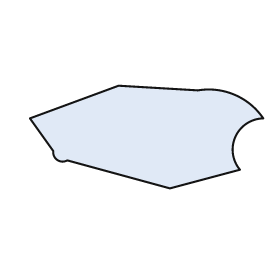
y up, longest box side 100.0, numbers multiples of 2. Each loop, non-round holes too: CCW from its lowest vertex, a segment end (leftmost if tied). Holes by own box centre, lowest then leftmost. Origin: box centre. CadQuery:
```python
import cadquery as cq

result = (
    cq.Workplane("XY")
    .moveTo(10.0, -22.0)
    .lineTo(40.0, -14.0)
    .threePointArc((38.0, 0.0), (50.0, 8.0))
    .threePointArc((38.0, 18.0), (22.0, 20.0))
    .lineTo(-12.0, 22.0)
    .lineTo(-50.0, 8.0)
    .lineTo(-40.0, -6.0)
    .threePointArc((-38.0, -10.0), (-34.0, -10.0))
    .close()
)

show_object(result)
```